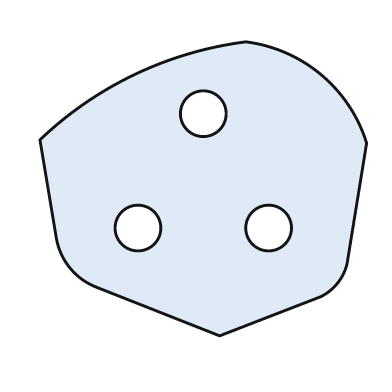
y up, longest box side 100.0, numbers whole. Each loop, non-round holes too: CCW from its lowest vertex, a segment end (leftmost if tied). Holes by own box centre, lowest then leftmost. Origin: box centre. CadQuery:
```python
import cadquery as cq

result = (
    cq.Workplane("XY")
    .moveTo(5.0, -45.0)
    .lineTo(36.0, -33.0)
    .threePointArc((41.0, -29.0), (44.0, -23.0))
    .lineTo(50.0, 14.0)
    .threePointArc((36.0, 35.0), (13.0, 45.0))
    .threePointArc((-21.0, 35.0), (-50.0, 15.0))
    .lineTo(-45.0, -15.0)
    .threePointArc((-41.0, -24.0), (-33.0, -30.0))
    .close()
    .moveTo(-20.0, -12.0)
    .circle(7.0)
    .moveTo(20.0, -12.0)
    .circle(7.0)
    .moveTo(0.0, 23.0)
    .circle(7.0)
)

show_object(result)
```